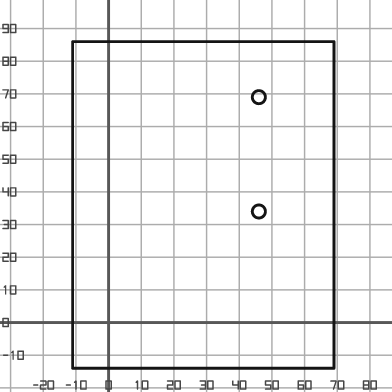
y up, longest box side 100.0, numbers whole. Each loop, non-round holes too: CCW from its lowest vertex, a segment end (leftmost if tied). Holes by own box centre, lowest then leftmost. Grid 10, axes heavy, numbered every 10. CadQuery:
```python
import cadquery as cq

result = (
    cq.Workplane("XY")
    .moveTo(-11.0, -14.0)
    .lineTo(69.0, -14.0)
    .lineTo(69.0, 86.0)
    .lineTo(-11.0, 86.0)
    .close()
    .moveTo(46.0, 34.0)
    .circle(2.0)
    .moveTo(46.0, 69.0)
    .circle(2.0)
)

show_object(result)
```